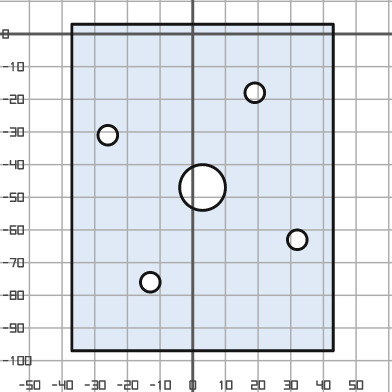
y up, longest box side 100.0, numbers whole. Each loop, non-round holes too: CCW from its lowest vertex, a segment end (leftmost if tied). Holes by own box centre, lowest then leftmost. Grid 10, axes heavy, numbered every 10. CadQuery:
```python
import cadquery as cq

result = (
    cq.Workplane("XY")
    .moveTo(-37.0, -97.0)
    .lineTo(43.0, -97.0)
    .lineTo(43.0, 3.0)
    .lineTo(-37.0, 3.0)
    .close()
    .moveTo(-13.0, -76.0)
    .circle(3.0)
    .moveTo(32.0, -63.0)
    .circle(3.0)
    .moveTo(3.0, -47.0)
    .circle(7.0)
    .moveTo(-26.0, -31.0)
    .circle(3.0)
    .moveTo(19.0, -18.0)
    .circle(3.0)
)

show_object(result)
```